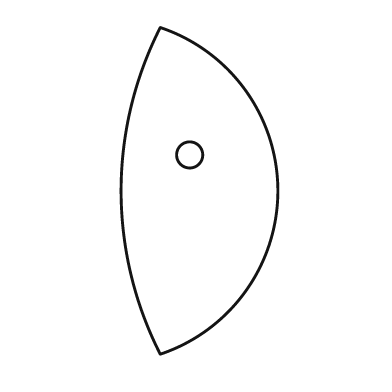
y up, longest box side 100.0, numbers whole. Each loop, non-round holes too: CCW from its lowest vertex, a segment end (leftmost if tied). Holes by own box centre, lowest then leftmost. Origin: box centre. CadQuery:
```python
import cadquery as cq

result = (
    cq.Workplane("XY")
    .moveTo(-12.0, -50.0)
    .threePointArc((24.0, 0.0), (-12.0, 50.0))
    .threePointArc((-24.0, 0.0), (-12.0, -50.0))
    .close()
    .moveTo(-3.0, 11.0)
    .circle(4.0)
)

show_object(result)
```